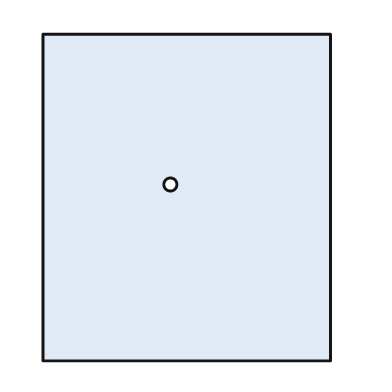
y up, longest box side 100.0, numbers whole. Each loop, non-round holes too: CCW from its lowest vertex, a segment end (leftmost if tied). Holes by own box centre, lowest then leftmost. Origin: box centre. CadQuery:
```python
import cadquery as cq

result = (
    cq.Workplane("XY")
    .moveTo(-44.0, -50.0)
    .lineTo(44.0, -50.0)
    .lineTo(44.0, 50.0)
    .lineTo(-44.0, 50.0)
    .close()
    .moveTo(-5.0, 4.0)
    .circle(2.0)
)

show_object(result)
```